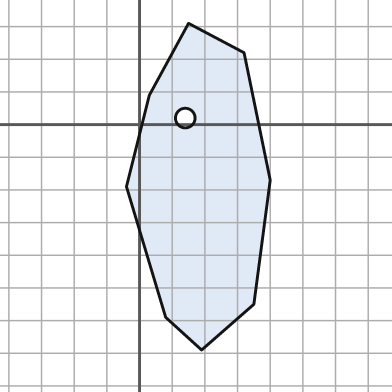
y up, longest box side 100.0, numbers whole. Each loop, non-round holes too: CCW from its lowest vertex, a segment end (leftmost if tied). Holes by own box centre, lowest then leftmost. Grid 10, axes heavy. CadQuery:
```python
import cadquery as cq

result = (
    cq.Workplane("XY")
    .moveTo(19.0, -69.0)
    .lineTo(35.0, -55.0)
    .lineTo(40.0, -17.0)
    .lineTo(32.0, 22.0)
    .lineTo(15.0, 31.0)
    .lineTo(3.0, 9.0)
    .lineTo(-4.0, -19.0)
    .lineTo(8.0, -59.0)
    .close()
    .moveTo(14.0, 2.0)
    .circle(3.0)
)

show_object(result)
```